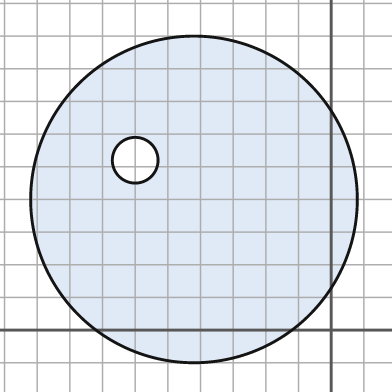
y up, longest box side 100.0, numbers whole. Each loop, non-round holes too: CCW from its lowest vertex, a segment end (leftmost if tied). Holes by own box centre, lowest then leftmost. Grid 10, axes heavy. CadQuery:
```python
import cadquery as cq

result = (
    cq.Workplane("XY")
    .moveTo(-42.0, 40.0)
    .circle(50.0)
    .moveTo(-60.0, 52.0)
    .circle(7.0)
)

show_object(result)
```